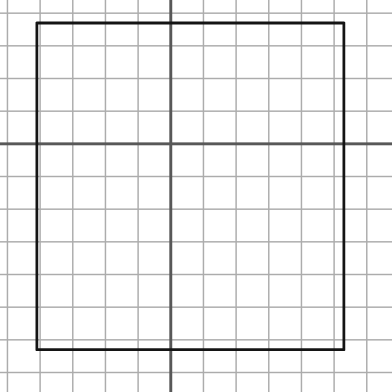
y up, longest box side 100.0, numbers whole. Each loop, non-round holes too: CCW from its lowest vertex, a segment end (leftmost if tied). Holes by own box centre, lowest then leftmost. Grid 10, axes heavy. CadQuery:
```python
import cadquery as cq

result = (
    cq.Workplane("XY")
    .moveTo(-41.0, -63.0)
    .lineTo(53.0, -63.0)
    .lineTo(53.0, 37.0)
    .lineTo(-41.0, 37.0)
    .close()
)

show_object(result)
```